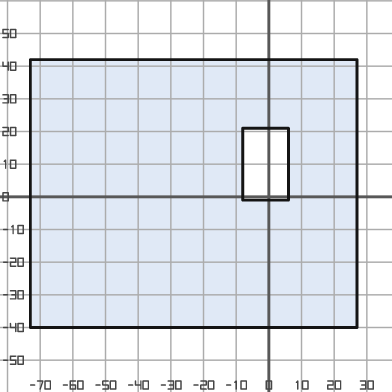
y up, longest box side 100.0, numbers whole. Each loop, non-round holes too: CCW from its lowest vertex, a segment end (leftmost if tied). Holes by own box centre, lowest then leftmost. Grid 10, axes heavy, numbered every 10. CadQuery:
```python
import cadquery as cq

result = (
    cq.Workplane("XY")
    .moveTo(-73.0, -40.0)
    .lineTo(27.0, -40.0)
    .lineTo(27.0, 42.0)
    .lineTo(-73.0, 42.0)
    .close()
    .moveTo(-8.0, -1.0)
    .lineTo(6.0, -1.0)
    .lineTo(6.0, 21.0)
    .lineTo(-8.0, 21.0)
    .close()
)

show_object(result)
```